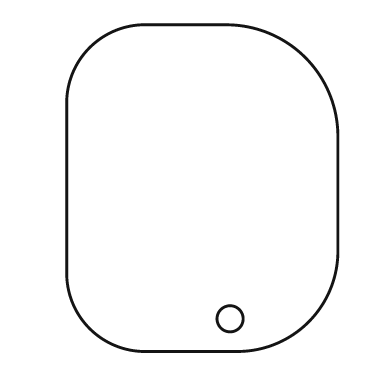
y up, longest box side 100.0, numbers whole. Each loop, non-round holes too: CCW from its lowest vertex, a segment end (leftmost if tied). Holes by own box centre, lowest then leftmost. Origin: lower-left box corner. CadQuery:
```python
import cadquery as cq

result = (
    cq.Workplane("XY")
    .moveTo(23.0, 0.0)
    .lineTo(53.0, 0.0)
    .threePointArc((74.0, 9.0), (83.0, 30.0))
    .lineTo(83.0, 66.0)
    .threePointArc((73.0, 90.0), (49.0, 100.0))
    .lineTo(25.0, 100.0)
    .threePointArc((7.0, 93.0), (0.0, 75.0))
    .lineTo(0.0, 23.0)
    .threePointArc((7.0, 7.0), (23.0, 0.0))
    .close()
    .moveTo(50.0, 10.0)
    .circle(4.0)
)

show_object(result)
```